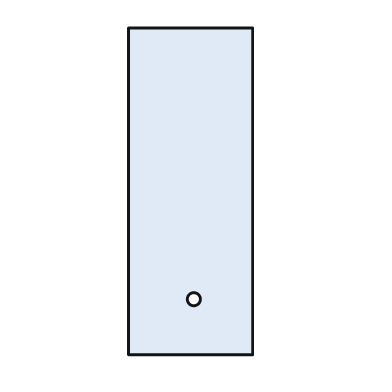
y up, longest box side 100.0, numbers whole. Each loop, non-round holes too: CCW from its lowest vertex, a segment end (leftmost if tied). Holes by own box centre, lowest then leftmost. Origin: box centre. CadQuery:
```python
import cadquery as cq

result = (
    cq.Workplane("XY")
    .moveTo(-19.0, -50.0)
    .lineTo(19.0, -50.0)
    .lineTo(19.0, 50.0)
    .lineTo(-19.0, 50.0)
    .close()
    .moveTo(1.0, -33.0)
    .circle(2.0)
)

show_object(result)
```